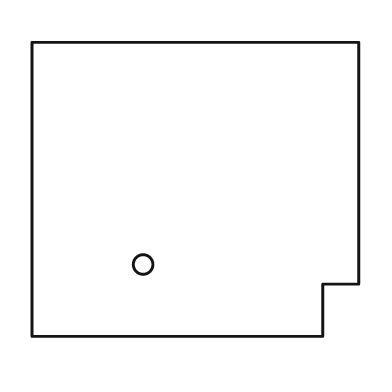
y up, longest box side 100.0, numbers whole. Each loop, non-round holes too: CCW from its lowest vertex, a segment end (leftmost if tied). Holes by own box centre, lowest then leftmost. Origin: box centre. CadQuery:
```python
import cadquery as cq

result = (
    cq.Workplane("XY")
    .moveTo(-50.0, -45.0)
    .lineTo(39.0, -45.0)
    .lineTo(39.0, -29.0)
    .lineTo(50.0, -29.0)
    .lineTo(50.0, 45.0)
    .lineTo(-50.0, 45.0)
    .close()
    .moveTo(-16.0, -23.0)
    .circle(3.0)
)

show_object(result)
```